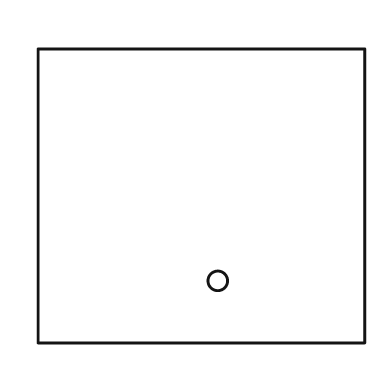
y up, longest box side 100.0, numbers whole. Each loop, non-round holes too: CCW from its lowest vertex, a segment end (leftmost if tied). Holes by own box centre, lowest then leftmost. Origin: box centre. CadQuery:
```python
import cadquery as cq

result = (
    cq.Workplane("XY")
    .moveTo(-50.0, -45.0)
    .lineTo(50.0, -45.0)
    .lineTo(50.0, 45.0)
    .lineTo(-50.0, 45.0)
    .close()
    .moveTo(5.0, -26.0)
    .circle(3.0)
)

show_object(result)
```